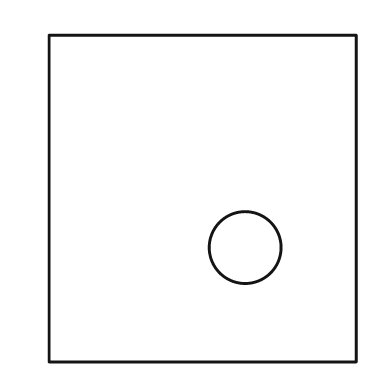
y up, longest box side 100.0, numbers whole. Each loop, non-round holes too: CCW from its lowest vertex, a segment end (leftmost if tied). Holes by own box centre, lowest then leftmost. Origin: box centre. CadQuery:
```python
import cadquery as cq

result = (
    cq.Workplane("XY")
    .moveTo(-47.0, -50.0)
    .lineTo(47.0, -50.0)
    .lineTo(47.0, 50.0)
    .lineTo(-47.0, 50.0)
    .close()
    .moveTo(13.0, -15.0)
    .circle(11.0)
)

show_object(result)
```